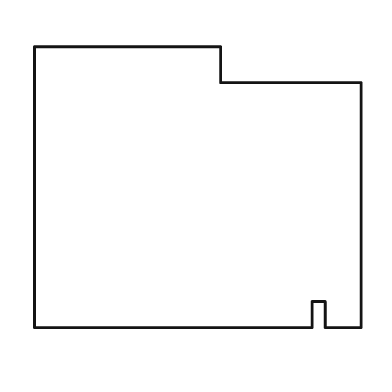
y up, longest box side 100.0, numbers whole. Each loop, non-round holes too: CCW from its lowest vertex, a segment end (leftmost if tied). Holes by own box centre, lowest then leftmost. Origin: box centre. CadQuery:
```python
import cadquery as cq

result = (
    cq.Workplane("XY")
    .moveTo(-50.0, -43.0)
    .lineTo(35.0, -43.0)
    .lineTo(35.0, -35.0)
    .lineTo(39.0, -35.0)
    .lineTo(39.0, -43.0)
    .lineTo(50.0, -43.0)
    .lineTo(50.0, 32.0)
    .lineTo(7.0, 32.0)
    .lineTo(7.0, 43.0)
    .lineTo(-50.0, 43.0)
    .close()
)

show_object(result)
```